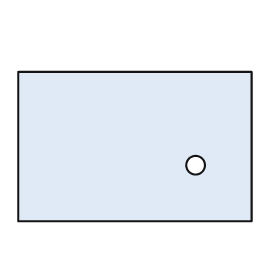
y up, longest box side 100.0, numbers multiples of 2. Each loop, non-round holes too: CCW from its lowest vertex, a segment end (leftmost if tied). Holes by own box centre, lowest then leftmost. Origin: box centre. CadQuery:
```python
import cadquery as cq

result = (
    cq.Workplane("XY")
    .moveTo(-50.0, -32.0)
    .lineTo(50.0, -32.0)
    .lineTo(50.0, 32.0)
    .lineTo(-50.0, 32.0)
    .close()
    .moveTo(26.0, -8.0)
    .circle(4.0)
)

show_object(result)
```